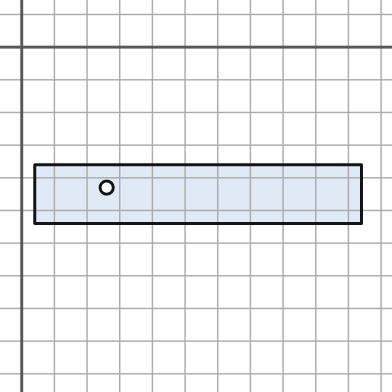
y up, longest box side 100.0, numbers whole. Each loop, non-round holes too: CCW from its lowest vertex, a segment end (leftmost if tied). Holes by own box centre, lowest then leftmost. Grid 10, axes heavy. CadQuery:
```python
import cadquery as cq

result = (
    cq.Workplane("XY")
    .moveTo(4.0, -54.0)
    .lineTo(104.0, -54.0)
    .lineTo(104.0, -36.0)
    .lineTo(4.0, -36.0)
    .close()
    .moveTo(26.0, -43.0)
    .circle(2.0)
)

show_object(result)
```